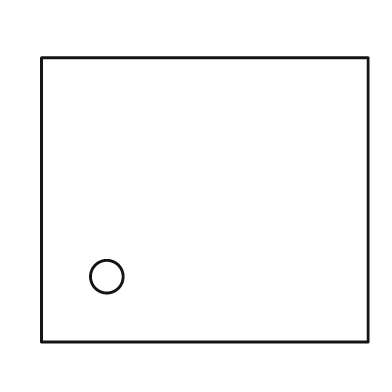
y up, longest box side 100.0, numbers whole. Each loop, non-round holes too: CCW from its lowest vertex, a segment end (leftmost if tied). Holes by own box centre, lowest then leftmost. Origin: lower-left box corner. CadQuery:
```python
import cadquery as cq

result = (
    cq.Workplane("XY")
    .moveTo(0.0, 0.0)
    .lineTo(100.0, 0.0)
    .lineTo(100.0, 87.0)
    .lineTo(0.0, 87.0)
    .close()
    .moveTo(20.0, 20.0)
    .circle(5.0)
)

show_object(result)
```